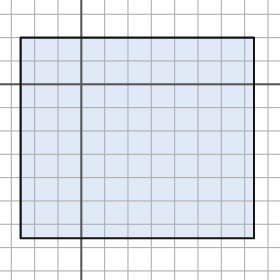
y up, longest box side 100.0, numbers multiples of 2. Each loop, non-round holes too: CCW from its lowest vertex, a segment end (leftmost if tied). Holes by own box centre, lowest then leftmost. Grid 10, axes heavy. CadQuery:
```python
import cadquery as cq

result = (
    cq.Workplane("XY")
    .moveTo(-26.0, -66.0)
    .lineTo(74.0, -66.0)
    .lineTo(74.0, 20.0)
    .lineTo(-26.0, 20.0)
    .close()
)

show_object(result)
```